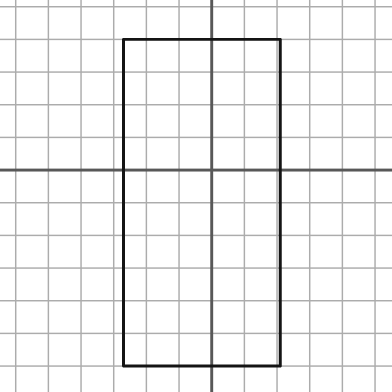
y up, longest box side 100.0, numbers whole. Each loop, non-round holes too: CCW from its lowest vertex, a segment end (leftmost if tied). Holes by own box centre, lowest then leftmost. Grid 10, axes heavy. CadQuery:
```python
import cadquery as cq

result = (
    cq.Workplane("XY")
    .moveTo(-27.0, -60.0)
    .lineTo(21.0, -60.0)
    .lineTo(21.0, 40.0)
    .lineTo(-27.0, 40.0)
    .close()
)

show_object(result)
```